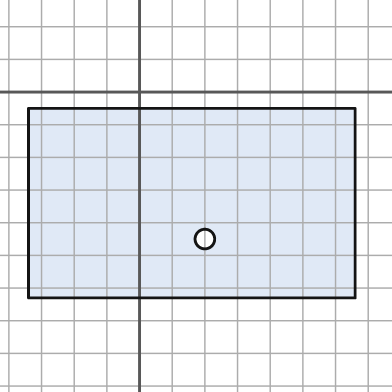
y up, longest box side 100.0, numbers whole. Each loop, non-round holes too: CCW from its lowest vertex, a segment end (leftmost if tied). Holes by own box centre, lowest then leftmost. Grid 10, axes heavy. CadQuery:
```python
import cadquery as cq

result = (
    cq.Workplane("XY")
    .moveTo(-34.0, -63.0)
    .lineTo(66.0, -63.0)
    .lineTo(66.0, -5.0)
    .lineTo(-34.0, -5.0)
    .close()
    .moveTo(20.0, -45.0)
    .circle(3.0)
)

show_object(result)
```